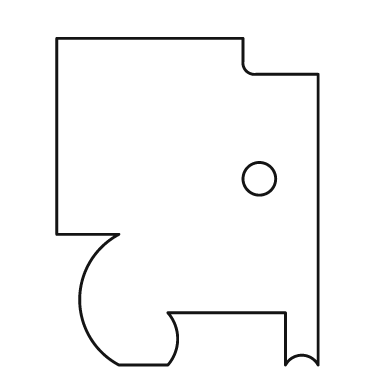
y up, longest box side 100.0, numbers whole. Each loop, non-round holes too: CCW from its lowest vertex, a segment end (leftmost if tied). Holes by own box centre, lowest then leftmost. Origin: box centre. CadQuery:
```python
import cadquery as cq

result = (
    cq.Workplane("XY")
    .moveTo(-21.0, -50.0)
    .lineTo(-6.0, -50.0)
    .threePointArc((-3.0, -42.0), (-6.0, -34.0))
    .lineTo(30.0, -34.0)
    .lineTo(30.0, -50.0)
    .threePointArc((35.0, -47.0), (40.0, -50.0))
    .lineTo(40.0, 39.0)
    .lineTo(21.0, 39.0)
    .threePointArc((18.0, 40.0), (17.0, 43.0))
    .lineTo(17.0, 50.0)
    .lineTo(-40.0, 50.0)
    .lineTo(-40.0, -10.0)
    .lineTo(-21.0, -10.0)
    .threePointArc((-33.0, -30.0), (-21.0, -50.0))
    .close()
    .moveTo(22.0, 7.0)
    .circle(5.0)
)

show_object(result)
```